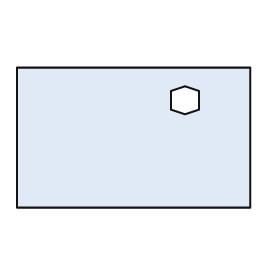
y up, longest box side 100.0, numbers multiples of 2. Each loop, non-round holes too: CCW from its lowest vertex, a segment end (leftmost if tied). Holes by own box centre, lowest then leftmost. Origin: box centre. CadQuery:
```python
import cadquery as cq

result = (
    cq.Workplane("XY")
    .moveTo(-50.0, -30.0)
    .lineTo(50.0, -30.0)
    .lineTo(50.0, 30.0)
    .lineTo(-50.0, 30.0)
    .close()
    .moveTo(22.0, 10.0)
    .lineTo(28.0, 12.0)
    .lineTo(28.0, 20.0)
    .lineTo(22.0, 22.0)
    .lineTo(16.0, 20.0)
    .lineTo(16.0, 12.0)
    .close()
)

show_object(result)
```